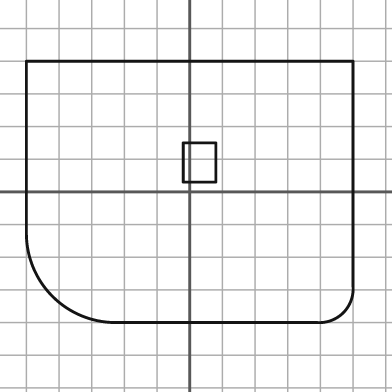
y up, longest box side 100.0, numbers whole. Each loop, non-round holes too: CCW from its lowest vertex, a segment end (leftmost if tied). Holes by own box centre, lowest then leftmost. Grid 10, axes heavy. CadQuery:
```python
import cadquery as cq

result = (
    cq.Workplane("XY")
    .moveTo(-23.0, -40.0)
    .lineTo(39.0, -40.0)
    .threePointArc((47.0, -37.0), (50.0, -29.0))
    .lineTo(50.0, 40.0)
    .lineTo(-50.0, 40.0)
    .lineTo(-50.0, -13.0)
    .threePointArc((-42.0, -32.0), (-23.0, -40.0))
    .close()
    .moveTo(-2.0, 3.0)
    .lineTo(8.0, 3.0)
    .lineTo(8.0, 15.0)
    .lineTo(-2.0, 15.0)
    .close()
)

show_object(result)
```